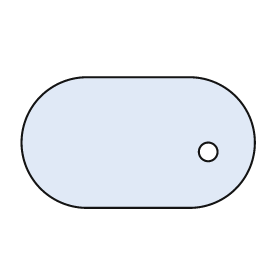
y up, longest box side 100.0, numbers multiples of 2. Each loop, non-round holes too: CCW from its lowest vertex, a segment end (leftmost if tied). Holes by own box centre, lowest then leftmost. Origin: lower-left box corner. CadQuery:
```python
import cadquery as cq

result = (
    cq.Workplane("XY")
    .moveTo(28.0, 0.0)
    .lineTo(72.0, 0.0)
    .threePointArc((100.0, 28.0), (72.0, 56.0))
    .lineTo(28.0, 56.0)
    .threePointArc((0.0, 28.0), (28.0, 0.0))
    .close()
    .moveTo(80.0, 24.0)
    .circle(4.0)
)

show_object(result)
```